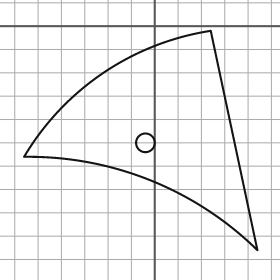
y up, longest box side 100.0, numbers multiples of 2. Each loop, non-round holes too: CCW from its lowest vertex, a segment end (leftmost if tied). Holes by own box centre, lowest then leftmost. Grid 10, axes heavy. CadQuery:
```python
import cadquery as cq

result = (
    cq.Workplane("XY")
    .moveTo(44.0, -96.0)
    .lineTo(24.0, -2.0)
    .threePointArc((-22.0, -20.0), (-56.0, -56.0))
    .threePointArc((-2.0, -66.0), (44.0, -96.0))
    .close()
    .moveTo(-4.0, -50.0)
    .circle(4.0)
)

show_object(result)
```